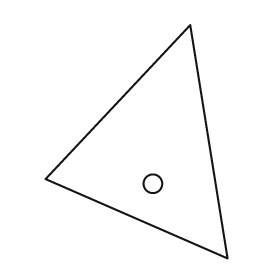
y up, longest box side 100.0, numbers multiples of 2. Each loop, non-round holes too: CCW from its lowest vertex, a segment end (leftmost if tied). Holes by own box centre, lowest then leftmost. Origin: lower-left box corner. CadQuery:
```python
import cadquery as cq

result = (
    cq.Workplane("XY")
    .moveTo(78.0, 0.0)
    .lineTo(62.0, 100.0)
    .lineTo(0.0, 34.0)
    .close()
    .moveTo(46.0, 32.0)
    .circle(4.0)
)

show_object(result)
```